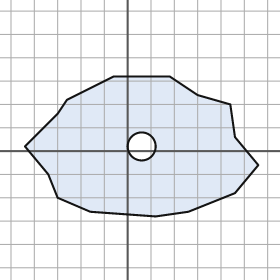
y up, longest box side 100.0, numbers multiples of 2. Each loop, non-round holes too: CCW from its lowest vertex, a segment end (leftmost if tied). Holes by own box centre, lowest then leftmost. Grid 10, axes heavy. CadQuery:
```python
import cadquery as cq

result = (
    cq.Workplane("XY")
    .moveTo(12.0, -28.0)
    .lineTo(26.0, -26.0)
    .lineTo(46.0, -18.0)
    .lineTo(56.0, -6.0)
    .lineTo(46.0, 6.0)
    .lineTo(44.0, 20.0)
    .lineTo(30.0, 24.0)
    .lineTo(18.0, 32.0)
    .lineTo(-6.0, 32.0)
    .lineTo(-26.0, 22.0)
    .lineTo(-30.0, 16.0)
    .lineTo(-44.0, 2.0)
    .lineTo(-34.0, -10.0)
    .lineTo(-30.0, -20.0)
    .lineTo(-16.0, -26.0)
    .close()
    .moveTo(6.0, 2.0)
    .circle(6.0)
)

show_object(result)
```